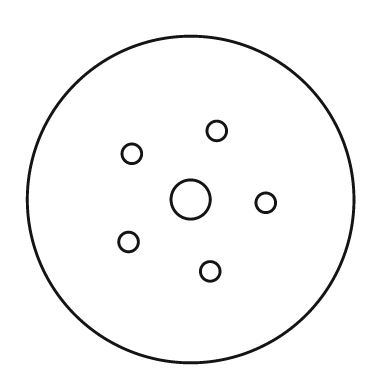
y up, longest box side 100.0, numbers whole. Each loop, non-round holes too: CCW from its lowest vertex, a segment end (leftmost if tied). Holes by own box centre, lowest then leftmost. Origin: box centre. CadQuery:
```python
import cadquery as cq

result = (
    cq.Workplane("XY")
    .moveTo(0.0, 0.0)
    .circle(50.0)
    .moveTo(6.0, -22.0)
    .circle(3.0)
    .moveTo(-19.0, -13.0)
    .circle(3.0)
    .moveTo(23.0, -1.0)
    .circle(3.0)
    .moveTo(0.0, 0.0)
    .circle(6.0)
    .moveTo(-18.0, 14.0)
    .circle(3.0)
    .moveTo(8.0, 21.0)
    .circle(3.0)
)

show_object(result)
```